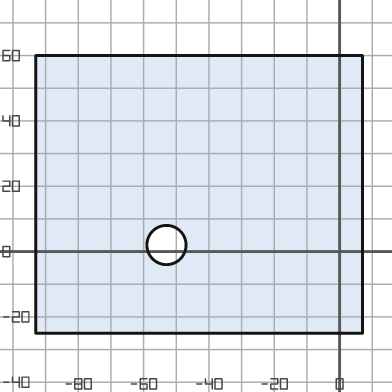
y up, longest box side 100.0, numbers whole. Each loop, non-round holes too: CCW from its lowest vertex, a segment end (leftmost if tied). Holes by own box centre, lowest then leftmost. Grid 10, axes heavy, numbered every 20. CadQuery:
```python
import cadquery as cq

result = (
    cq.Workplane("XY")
    .moveTo(-93.0, -25.0)
    .lineTo(7.0, -25.0)
    .lineTo(7.0, 60.0)
    .lineTo(-93.0, 60.0)
    .close()
    .moveTo(-53.0, 2.0)
    .circle(6.0)
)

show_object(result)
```